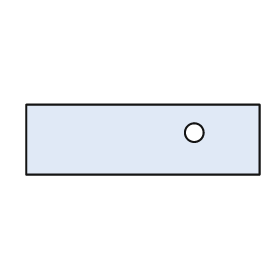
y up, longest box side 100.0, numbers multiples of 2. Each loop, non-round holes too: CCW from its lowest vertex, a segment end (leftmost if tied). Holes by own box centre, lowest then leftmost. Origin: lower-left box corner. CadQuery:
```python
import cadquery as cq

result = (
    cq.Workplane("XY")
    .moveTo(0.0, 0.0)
    .lineTo(100.0, 0.0)
    .lineTo(100.0, 30.0)
    .lineTo(0.0, 30.0)
    .close()
    .moveTo(72.0, 18.0)
    .circle(4.0)
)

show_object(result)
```